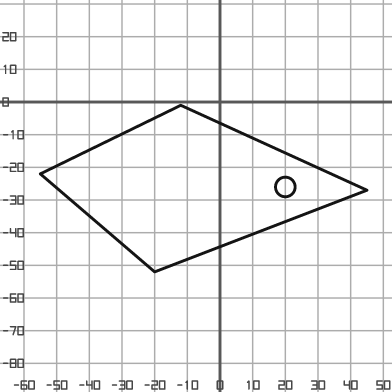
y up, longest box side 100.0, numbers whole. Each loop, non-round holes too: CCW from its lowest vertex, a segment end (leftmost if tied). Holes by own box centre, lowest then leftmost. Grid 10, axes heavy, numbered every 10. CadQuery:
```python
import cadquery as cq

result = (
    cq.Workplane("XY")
    .moveTo(-20.0, -52.0)
    .lineTo(45.0, -27.0)
    .lineTo(-12.0, -1.0)
    .lineTo(-55.0, -22.0)
    .close()
    .moveTo(20.0, -26.0)
    .circle(3.0)
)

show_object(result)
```